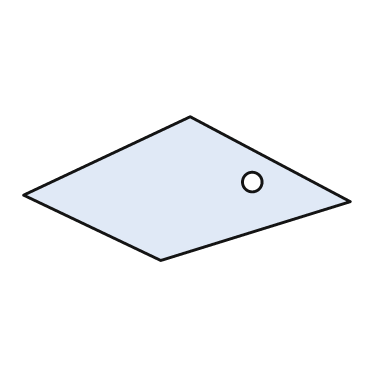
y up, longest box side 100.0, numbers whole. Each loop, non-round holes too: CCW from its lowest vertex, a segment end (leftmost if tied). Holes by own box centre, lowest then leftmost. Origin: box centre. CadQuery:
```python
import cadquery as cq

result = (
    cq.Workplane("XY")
    .moveTo(-8.0, -22.0)
    .lineTo(50.0, -4.0)
    .lineTo(1.0, 22.0)
    .lineTo(-50.0, -2.0)
    .close()
    .moveTo(20.0, 2.0)
    .circle(3.0)
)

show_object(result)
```